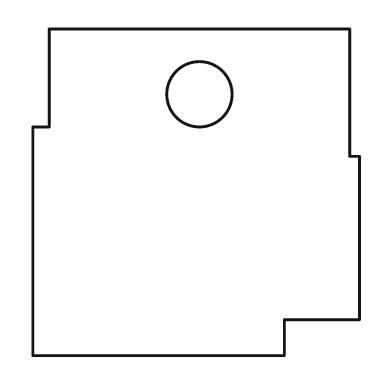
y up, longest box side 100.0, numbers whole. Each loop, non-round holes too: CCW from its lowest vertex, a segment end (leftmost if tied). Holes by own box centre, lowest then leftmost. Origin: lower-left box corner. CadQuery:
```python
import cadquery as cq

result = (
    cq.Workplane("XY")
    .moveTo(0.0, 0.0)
    .lineTo(77.0, 0.0)
    .lineTo(77.0, 11.0)
    .lineTo(100.0, 11.0)
    .lineTo(100.0, 61.0)
    .lineTo(97.0, 61.0)
    .lineTo(97.0, 100.0)
    .lineTo(5.0, 100.0)
    .lineTo(5.0, 70.0)
    .lineTo(0.0, 70.0)
    .close()
    .moveTo(51.0, 80.0)
    .circle(10.0)
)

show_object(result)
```